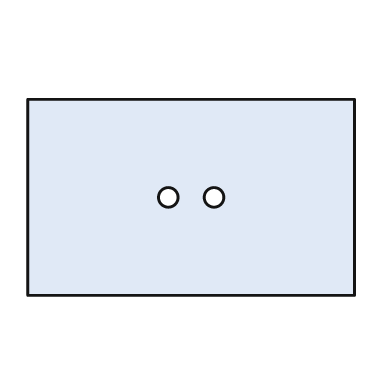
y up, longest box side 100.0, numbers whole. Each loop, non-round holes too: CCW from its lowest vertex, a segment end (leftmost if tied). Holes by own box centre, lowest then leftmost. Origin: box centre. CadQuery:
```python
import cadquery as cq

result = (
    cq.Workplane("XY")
    .moveTo(-50.0, -30.0)
    .lineTo(50.0, -30.0)
    .lineTo(50.0, 30.0)
    .lineTo(-50.0, 30.0)
    .close()
    .moveTo(-7.0, 0.0)
    .circle(3.0)
    .moveTo(7.0, 0.0)
    .circle(3.0)
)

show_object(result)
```